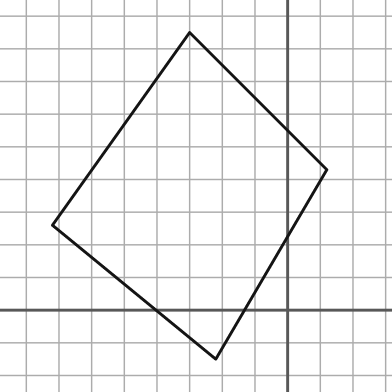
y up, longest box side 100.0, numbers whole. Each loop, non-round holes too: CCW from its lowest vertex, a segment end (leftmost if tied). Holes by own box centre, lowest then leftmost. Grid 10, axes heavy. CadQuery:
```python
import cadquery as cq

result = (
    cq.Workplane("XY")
    .moveTo(-22.0, -15.0)
    .lineTo(12.0, 43.0)
    .lineTo(-30.0, 85.0)
    .lineTo(-72.0, 26.0)
    .close()
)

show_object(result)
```